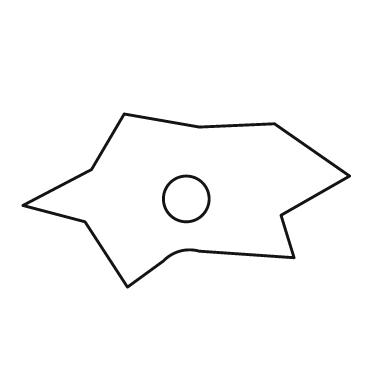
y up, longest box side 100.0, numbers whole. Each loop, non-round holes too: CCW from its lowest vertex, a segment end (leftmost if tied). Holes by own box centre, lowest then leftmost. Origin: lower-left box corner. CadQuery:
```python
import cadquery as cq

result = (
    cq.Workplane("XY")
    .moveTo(32.0, 0.0)
    .lineTo(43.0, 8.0)
    .threePointArc((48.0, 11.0), (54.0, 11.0))
    .lineTo(83.0, 9.0)
    .lineTo(79.0, 22.0)
    .lineTo(100.0, 34.0)
    .lineTo(77.0, 50.0)
    .lineTo(54.0, 49.0)
    .lineTo(31.0, 53.0)
    .lineTo(21.0, 36.0)
    .lineTo(0.0, 25.0)
    .lineTo(19.0, 20.0)
    .close()
    .moveTo(50.0, 27.0)
    .circle(7.0)
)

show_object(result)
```